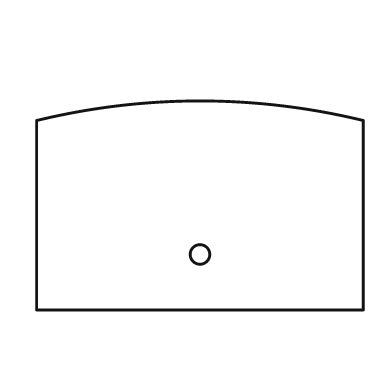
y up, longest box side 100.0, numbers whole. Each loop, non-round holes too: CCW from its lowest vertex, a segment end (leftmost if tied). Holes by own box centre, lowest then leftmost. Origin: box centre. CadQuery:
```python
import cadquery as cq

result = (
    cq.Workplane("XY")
    .moveTo(-50.0, -32.0)
    .lineTo(50.0, -32.0)
    .lineTo(50.0, 26.0)
    .threePointArc((0.0, 32.0), (-50.0, 26.0))
    .close()
    .moveTo(0.0, -15.0)
    .circle(3.0)
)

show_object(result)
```